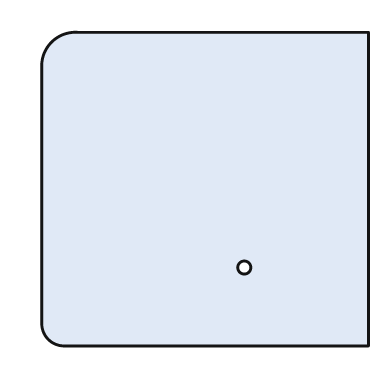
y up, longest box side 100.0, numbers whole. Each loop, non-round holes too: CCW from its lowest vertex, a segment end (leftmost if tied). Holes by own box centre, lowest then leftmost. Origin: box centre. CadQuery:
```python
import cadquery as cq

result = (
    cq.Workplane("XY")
    .moveTo(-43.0, -48.0)
    .lineTo(50.0, -48.0)
    .lineTo(50.0, 48.0)
    .lineTo(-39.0, 48.0)
    .threePointArc((-47.0, 45.0), (-50.0, 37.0))
    .lineTo(-50.0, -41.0)
    .threePointArc((-48.0, -46.0), (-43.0, -48.0))
    .close()
    .moveTo(12.0, -24.0)
    .circle(2.0)
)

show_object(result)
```